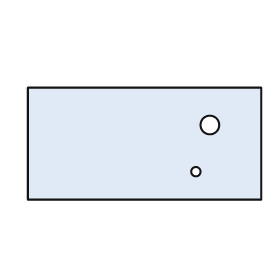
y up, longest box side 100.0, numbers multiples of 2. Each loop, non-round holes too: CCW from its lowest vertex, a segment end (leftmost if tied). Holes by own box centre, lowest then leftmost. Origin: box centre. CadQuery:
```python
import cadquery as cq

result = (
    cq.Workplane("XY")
    .moveTo(-50.0, -24.0)
    .lineTo(50.0, -24.0)
    .lineTo(50.0, 24.0)
    .lineTo(-50.0, 24.0)
    .close()
    .moveTo(22.0, -12.0)
    .circle(2.0)
    .moveTo(28.0, 8.0)
    .circle(4.0)
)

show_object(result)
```